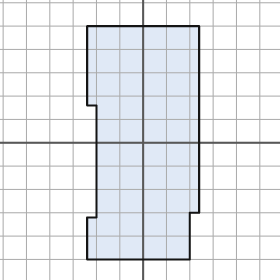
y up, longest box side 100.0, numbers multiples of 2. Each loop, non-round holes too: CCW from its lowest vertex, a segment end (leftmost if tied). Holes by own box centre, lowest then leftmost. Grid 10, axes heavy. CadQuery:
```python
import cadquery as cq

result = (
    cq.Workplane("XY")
    .moveTo(-24.0, -50.0)
    .lineTo(20.0, -50.0)
    .lineTo(20.0, -30.0)
    .lineTo(24.0, -30.0)
    .lineTo(24.0, 50.0)
    .lineTo(-24.0, 50.0)
    .lineTo(-24.0, 16.0)
    .lineTo(-20.0, 16.0)
    .lineTo(-20.0, -32.0)
    .lineTo(-24.0, -32.0)
    .close()
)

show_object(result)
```